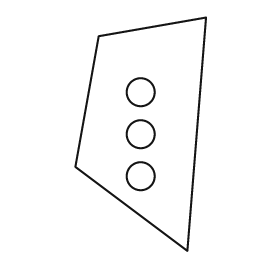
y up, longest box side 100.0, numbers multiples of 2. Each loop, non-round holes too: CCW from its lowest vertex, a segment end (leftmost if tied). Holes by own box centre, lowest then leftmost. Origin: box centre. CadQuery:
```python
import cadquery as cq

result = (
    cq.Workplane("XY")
    .moveTo(20.0, -50.0)
    .lineTo(28.0, 50.0)
    .lineTo(-18.0, 42.0)
    .lineTo(-28.0, -14.0)
    .close()
    .moveTo(0.0, -18.0)
    .circle(6.0)
    .moveTo(0.0, 0.0)
    .circle(6.0)
    .moveTo(0.0, 18.0)
    .circle(6.0)
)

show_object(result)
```